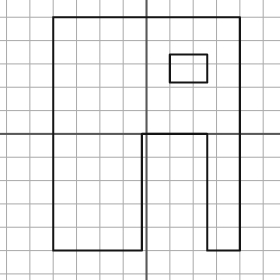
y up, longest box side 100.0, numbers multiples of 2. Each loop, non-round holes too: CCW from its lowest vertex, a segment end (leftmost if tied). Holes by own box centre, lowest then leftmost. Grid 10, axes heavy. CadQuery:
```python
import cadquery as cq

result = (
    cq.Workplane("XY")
    .moveTo(-40.0, -50.0)
    .lineTo(-2.0, -50.0)
    .lineTo(-2.0, 0.0)
    .lineTo(26.0, 0.0)
    .lineTo(26.0, -50.0)
    .lineTo(40.0, -50.0)
    .lineTo(40.0, 50.0)
    .lineTo(-40.0, 50.0)
    .close()
    .moveTo(10.0, 22.0)
    .lineTo(26.0, 22.0)
    .lineTo(26.0, 34.0)
    .lineTo(10.0, 34.0)
    .close()
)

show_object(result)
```